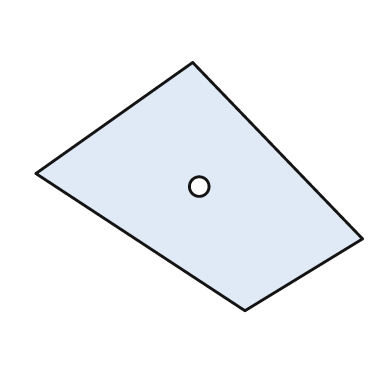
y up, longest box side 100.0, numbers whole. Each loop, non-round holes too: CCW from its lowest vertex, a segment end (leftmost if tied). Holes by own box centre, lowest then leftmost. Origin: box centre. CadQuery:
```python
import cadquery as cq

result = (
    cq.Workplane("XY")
    .moveTo(14.0, -38.0)
    .lineTo(50.0, -16.0)
    .lineTo(-2.0, 38.0)
    .lineTo(-50.0, 4.0)
    .close()
    .moveTo(0.0, 0.0)
    .circle(3.0)
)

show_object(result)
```